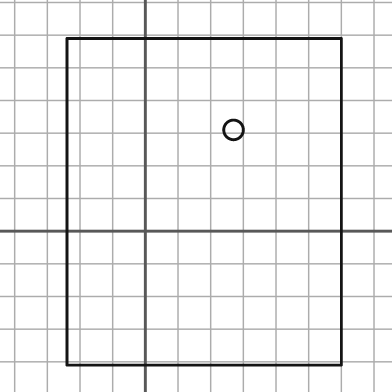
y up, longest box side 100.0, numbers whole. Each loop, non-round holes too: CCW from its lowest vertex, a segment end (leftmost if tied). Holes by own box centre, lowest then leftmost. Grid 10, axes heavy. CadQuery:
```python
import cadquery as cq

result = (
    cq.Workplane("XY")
    .moveTo(-24.0, -41.0)
    .lineTo(60.0, -41.0)
    .lineTo(60.0, 59.0)
    .lineTo(-24.0, 59.0)
    .close()
    .moveTo(27.0, 31.0)
    .circle(3.0)
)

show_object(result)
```